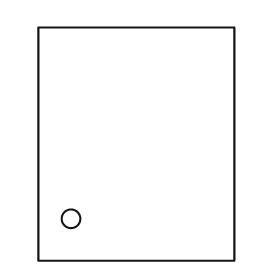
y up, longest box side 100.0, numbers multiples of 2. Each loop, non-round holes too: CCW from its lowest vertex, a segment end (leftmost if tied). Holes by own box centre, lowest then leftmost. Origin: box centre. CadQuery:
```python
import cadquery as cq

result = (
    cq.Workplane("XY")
    .moveTo(-42.0, -50.0)
    .lineTo(42.0, -50.0)
    .lineTo(42.0, 50.0)
    .lineTo(-42.0, 50.0)
    .close()
    .moveTo(-28.0, -32.0)
    .circle(4.0)
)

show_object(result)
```